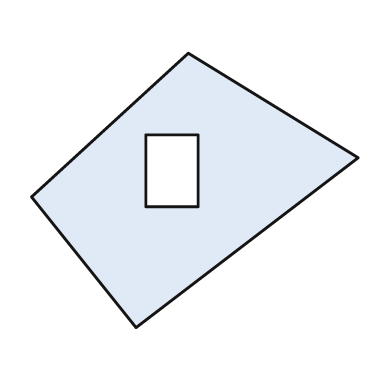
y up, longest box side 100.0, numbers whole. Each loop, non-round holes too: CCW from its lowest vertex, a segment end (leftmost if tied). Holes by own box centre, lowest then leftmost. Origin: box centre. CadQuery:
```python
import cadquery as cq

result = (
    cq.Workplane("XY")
    .moveTo(-18.0, -42.0)
    .lineTo(50.0, 10.0)
    .lineTo(-2.0, 42.0)
    .lineTo(-50.0, -2.0)
    .close()
    .moveTo(-15.0, -5.0)
    .lineTo(1.0, -5.0)
    .lineTo(1.0, 17.0)
    .lineTo(-15.0, 17.0)
    .close()
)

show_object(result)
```